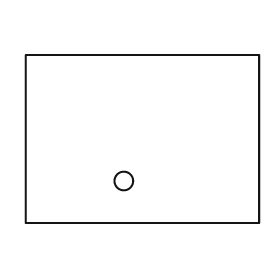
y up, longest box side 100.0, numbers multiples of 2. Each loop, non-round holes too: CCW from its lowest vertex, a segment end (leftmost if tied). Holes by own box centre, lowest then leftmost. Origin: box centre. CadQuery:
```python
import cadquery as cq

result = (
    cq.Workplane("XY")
    .moveTo(-50.0, -36.0)
    .lineTo(50.0, -36.0)
    .lineTo(50.0, 36.0)
    .lineTo(-50.0, 36.0)
    .close()
    .moveTo(-8.0, -18.0)
    .circle(4.0)
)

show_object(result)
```